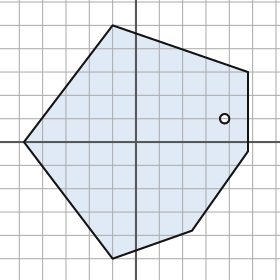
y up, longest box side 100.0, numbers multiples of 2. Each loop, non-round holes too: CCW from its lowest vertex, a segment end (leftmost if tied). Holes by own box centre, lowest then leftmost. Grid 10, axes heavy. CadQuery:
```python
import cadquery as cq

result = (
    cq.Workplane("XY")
    .moveTo(-10.0, -50.0)
    .lineTo(24.0, -38.0)
    .lineTo(48.0, -4.0)
    .lineTo(48.0, 30.0)
    .lineTo(-10.0, 50.0)
    .lineTo(-48.0, 0.0)
    .close()
    .moveTo(38.0, 10.0)
    .circle(2.0)
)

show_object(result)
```